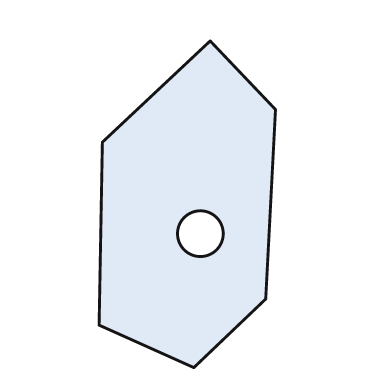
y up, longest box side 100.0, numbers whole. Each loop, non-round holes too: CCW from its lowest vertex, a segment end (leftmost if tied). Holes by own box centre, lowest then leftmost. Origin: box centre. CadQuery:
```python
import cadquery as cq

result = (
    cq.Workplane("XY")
    .moveTo(2.0, -50.0)
    .lineTo(24.0, -29.0)
    .lineTo(27.0, 29.0)
    .lineTo(7.0, 50.0)
    .lineTo(-26.0, 19.0)
    .lineTo(-27.0, -37.0)
    .close()
    .moveTo(4.0, -9.0)
    .circle(7.0)
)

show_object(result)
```